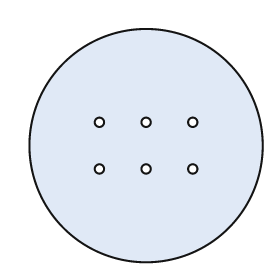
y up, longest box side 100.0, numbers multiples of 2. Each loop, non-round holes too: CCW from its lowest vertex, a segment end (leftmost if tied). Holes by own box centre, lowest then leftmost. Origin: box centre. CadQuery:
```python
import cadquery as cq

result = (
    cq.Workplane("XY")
    .moveTo(0.0, 0.0)
    .circle(50.0)
    .moveTo(-20.0, -10.0)
    .circle(2.0)
    .moveTo(0.0, -10.0)
    .circle(2.0)
    .moveTo(20.0, -10.0)
    .circle(2.0)
    .moveTo(-20.0, 10.0)
    .circle(2.0)
    .moveTo(0.0, 10.0)
    .circle(2.0)
    .moveTo(20.0, 10.0)
    .circle(2.0)
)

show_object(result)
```